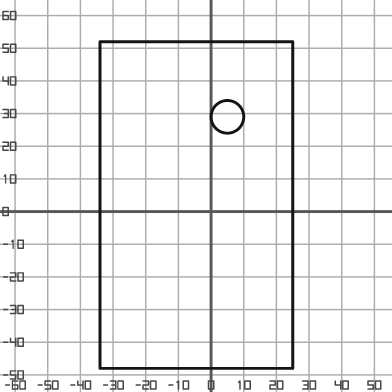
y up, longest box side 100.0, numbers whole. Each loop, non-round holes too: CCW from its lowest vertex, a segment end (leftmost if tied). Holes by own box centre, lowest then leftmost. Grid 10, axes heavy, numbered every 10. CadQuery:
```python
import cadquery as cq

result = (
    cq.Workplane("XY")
    .moveTo(-34.0, -48.0)
    .lineTo(25.0, -48.0)
    .lineTo(25.0, 52.0)
    .lineTo(-34.0, 52.0)
    .close()
    .moveTo(5.0, 29.0)
    .circle(5.0)
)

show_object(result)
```